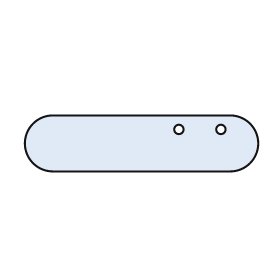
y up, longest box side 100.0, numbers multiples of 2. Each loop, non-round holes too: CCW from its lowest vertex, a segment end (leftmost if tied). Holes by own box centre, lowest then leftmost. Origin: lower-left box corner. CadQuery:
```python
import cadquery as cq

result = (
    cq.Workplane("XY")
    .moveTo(12.0, 0.0)
    .lineTo(88.0, 0.0)
    .threePointArc((100.0, 12.0), (88.0, 24.0))
    .lineTo(12.0, 24.0)
    .threePointArc((0.0, 12.0), (12.0, 0.0))
    .close()
    .moveTo(66.0, 18.0)
    .circle(2.0)
    .moveTo(84.0, 18.0)
    .circle(2.0)
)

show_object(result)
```